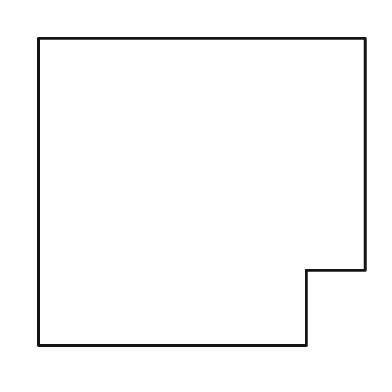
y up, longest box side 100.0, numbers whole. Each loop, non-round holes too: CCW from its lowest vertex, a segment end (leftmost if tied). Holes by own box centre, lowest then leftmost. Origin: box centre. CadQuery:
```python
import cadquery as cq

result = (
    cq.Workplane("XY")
    .moveTo(-50.0, -47.0)
    .lineTo(32.0, -47.0)
    .lineTo(32.0, -24.0)
    .lineTo(50.0, -24.0)
    .lineTo(50.0, 47.0)
    .lineTo(-50.0, 47.0)
    .close()
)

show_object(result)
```